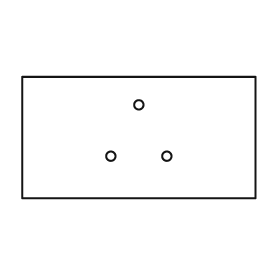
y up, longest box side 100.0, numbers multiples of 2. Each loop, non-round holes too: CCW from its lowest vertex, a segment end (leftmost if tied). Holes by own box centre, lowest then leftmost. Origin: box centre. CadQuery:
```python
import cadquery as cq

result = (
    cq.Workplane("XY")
    .moveTo(-50.0, -26.0)
    .lineTo(50.0, -26.0)
    .lineTo(50.0, 26.0)
    .lineTo(-50.0, 26.0)
    .close()
    .moveTo(-12.0, -8.0)
    .circle(2.0)
    .moveTo(12.0, -8.0)
    .circle(2.0)
    .moveTo(0.0, 14.0)
    .circle(2.0)
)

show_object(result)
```